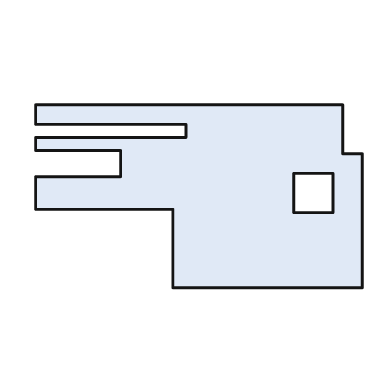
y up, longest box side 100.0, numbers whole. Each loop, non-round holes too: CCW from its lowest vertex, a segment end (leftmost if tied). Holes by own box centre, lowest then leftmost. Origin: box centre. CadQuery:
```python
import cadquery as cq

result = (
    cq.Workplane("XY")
    .moveTo(-8.0, -28.0)
    .lineTo(50.0, -28.0)
    .lineTo(50.0, 13.0)
    .lineTo(44.0, 13.0)
    .lineTo(44.0, 28.0)
    .lineTo(-50.0, 28.0)
    .lineTo(-50.0, 22.0)
    .lineTo(-4.0, 22.0)
    .lineTo(-4.0, 18.0)
    .lineTo(-50.0, 18.0)
    .lineTo(-50.0, 14.0)
    .lineTo(-24.0, 14.0)
    .lineTo(-24.0, 6.0)
    .lineTo(-50.0, 6.0)
    .lineTo(-50.0, -4.0)
    .lineTo(-8.0, -4.0)
    .close()
    .moveTo(29.0, -5.0)
    .lineTo(41.0, -5.0)
    .lineTo(41.0, 7.0)
    .lineTo(29.0, 7.0)
    .close()
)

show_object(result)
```